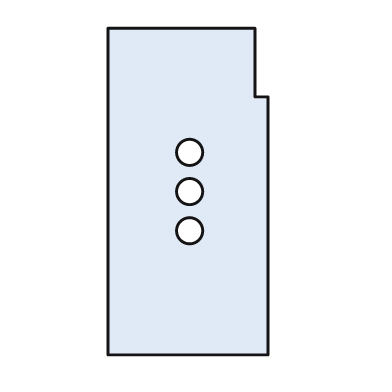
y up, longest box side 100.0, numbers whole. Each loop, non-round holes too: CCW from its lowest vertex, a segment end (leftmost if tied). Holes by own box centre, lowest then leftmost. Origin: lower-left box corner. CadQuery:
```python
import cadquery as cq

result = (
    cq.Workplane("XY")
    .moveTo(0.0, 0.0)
    .lineTo(49.0, 0.0)
    .lineTo(49.0, 79.0)
    .lineTo(45.0, 79.0)
    .lineTo(45.0, 100.0)
    .lineTo(0.0, 100.0)
    .close()
    .moveTo(25.0, 38.0)
    .circle(4.0)
    .moveTo(25.0, 50.0)
    .circle(4.0)
    .moveTo(25.0, 62.0)
    .circle(4.0)
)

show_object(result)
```